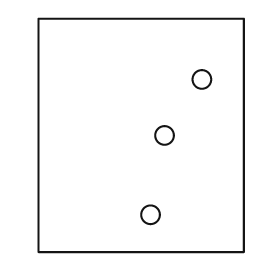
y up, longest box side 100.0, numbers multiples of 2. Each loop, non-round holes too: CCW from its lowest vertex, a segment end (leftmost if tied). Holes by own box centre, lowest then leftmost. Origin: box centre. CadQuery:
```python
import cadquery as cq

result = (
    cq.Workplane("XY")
    .moveTo(-44.0, -50.0)
    .lineTo(44.0, -50.0)
    .lineTo(44.0, 50.0)
    .lineTo(-44.0, 50.0)
    .close()
    .moveTo(4.0, -34.0)
    .circle(4.0)
    .moveTo(10.0, 0.0)
    .circle(4.0)
    .moveTo(26.0, 24.0)
    .circle(4.0)
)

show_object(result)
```